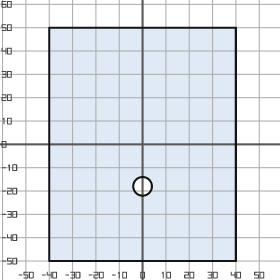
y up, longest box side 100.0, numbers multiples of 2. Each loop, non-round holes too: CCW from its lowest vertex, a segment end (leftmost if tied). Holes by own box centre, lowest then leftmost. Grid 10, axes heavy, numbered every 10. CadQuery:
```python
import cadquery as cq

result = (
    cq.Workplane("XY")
    .moveTo(-40.0, -50.0)
    .lineTo(40.0, -50.0)
    .lineTo(40.0, 50.0)
    .lineTo(-40.0, 50.0)
    .close()
    .moveTo(0.0, -18.0)
    .circle(4.0)
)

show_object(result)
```